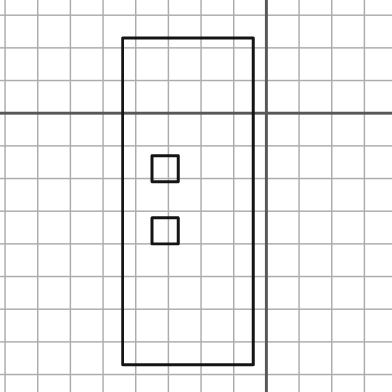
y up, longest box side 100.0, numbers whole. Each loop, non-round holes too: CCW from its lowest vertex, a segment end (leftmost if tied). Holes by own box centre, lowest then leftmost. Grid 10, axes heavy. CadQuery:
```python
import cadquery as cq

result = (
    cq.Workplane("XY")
    .moveTo(-44.0, -77.0)
    .lineTo(-4.0, -77.0)
    .lineTo(-4.0, 23.0)
    .lineTo(-44.0, 23.0)
    .close()
    .moveTo(-35.0, -40.0)
    .lineTo(-27.0, -40.0)
    .lineTo(-27.0, -32.0)
    .lineTo(-35.0, -32.0)
    .close()
    .moveTo(-35.0, -21.0)
    .lineTo(-27.0, -21.0)
    .lineTo(-27.0, -13.0)
    .lineTo(-35.0, -13.0)
    .close()
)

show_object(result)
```